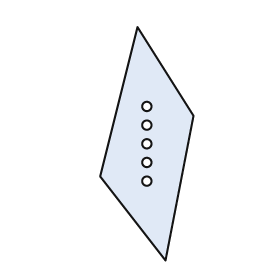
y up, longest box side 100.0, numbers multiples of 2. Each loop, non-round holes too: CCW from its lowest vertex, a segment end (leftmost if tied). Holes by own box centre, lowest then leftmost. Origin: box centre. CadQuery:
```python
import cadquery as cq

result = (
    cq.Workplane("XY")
    .moveTo(8.0, -50.0)
    .lineTo(20.0, 12.0)
    .lineTo(-4.0, 50.0)
    .lineTo(-20.0, -14.0)
    .close()
    .moveTo(0.0, -16.0)
    .circle(2.0)
    .moveTo(0.0, -8.0)
    .circle(2.0)
    .moveTo(0.0, 0.0)
    .circle(2.0)
    .moveTo(0.0, 8.0)
    .circle(2.0)
    .moveTo(0.0, 16.0)
    .circle(2.0)
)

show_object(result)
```